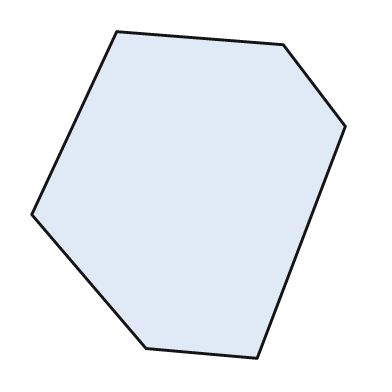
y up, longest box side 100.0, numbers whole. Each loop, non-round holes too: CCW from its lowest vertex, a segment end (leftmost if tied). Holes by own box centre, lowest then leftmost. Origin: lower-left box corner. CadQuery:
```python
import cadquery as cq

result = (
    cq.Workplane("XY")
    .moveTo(69.0, 0.0)
    .lineTo(96.0, 71.0)
    .lineTo(77.0, 96.0)
    .lineTo(26.0, 100.0)
    .lineTo(0.0, 44.0)
    .lineTo(35.0, 3.0)
    .close()
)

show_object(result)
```